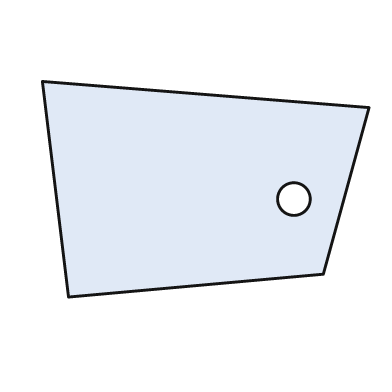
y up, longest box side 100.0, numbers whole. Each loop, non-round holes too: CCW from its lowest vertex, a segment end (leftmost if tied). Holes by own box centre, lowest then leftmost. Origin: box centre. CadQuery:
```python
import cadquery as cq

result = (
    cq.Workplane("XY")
    .moveTo(-42.0, -33.0)
    .lineTo(36.0, -26.0)
    .lineTo(50.0, 25.0)
    .lineTo(-50.0, 33.0)
    .close()
    .moveTo(27.0, -3.0)
    .circle(5.0)
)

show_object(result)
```